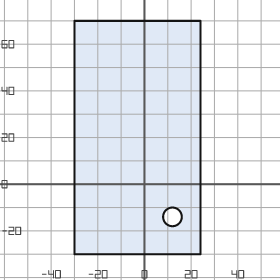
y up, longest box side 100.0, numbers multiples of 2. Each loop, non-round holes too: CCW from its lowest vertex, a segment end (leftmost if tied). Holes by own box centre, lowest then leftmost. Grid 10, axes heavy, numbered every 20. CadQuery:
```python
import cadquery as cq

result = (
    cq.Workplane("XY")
    .moveTo(-30.0, -30.0)
    .lineTo(24.0, -30.0)
    .lineTo(24.0, 70.0)
    .lineTo(-30.0, 70.0)
    .close()
    .moveTo(12.0, -14.0)
    .circle(4.0)
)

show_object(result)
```